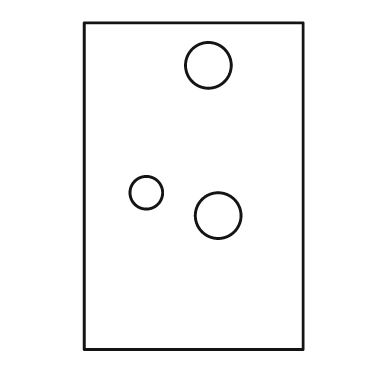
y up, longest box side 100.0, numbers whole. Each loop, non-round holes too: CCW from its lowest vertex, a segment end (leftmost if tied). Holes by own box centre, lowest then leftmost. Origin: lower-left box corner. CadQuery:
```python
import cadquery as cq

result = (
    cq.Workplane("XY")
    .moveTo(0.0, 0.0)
    .lineTo(67.0, 0.0)
    .lineTo(67.0, 100.0)
    .lineTo(0.0, 100.0)
    .close()
    .moveTo(41.0, 41.0)
    .circle(7.0)
    .moveTo(19.0, 48.0)
    .circle(5.0)
    .moveTo(38.0, 87.0)
    .circle(7.0)
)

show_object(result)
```